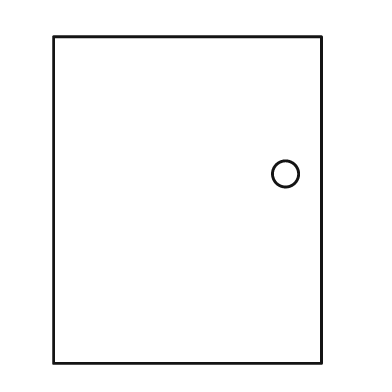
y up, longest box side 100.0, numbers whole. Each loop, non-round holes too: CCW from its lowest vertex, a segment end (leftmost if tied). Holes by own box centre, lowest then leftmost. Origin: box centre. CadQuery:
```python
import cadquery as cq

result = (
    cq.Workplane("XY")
    .moveTo(-41.0, -50.0)
    .lineTo(41.0, -50.0)
    .lineTo(41.0, 50.0)
    .lineTo(-41.0, 50.0)
    .close()
    .moveTo(30.0, 8.0)
    .circle(4.0)
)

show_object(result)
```